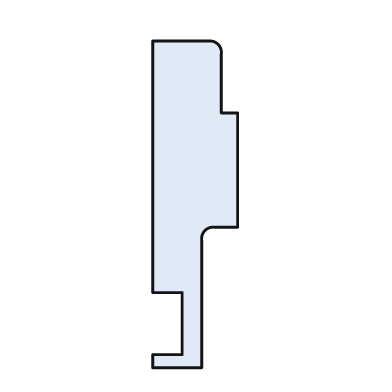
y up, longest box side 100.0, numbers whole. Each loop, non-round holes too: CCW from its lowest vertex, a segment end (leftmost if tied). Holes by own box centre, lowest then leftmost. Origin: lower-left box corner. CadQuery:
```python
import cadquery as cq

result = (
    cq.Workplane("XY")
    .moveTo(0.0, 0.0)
    .lineTo(15.0, 0.0)
    .lineTo(15.0, 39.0)
    .threePointArc((16.0, 42.0), (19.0, 43.0))
    .lineTo(26.0, 43.0)
    .lineTo(26.0, 78.0)
    .lineTo(21.0, 78.0)
    .lineTo(21.0, 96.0)
    .threePointArc((20.0, 99.0), (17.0, 100.0))
    .lineTo(0.0, 100.0)
    .lineTo(0.0, 23.0)
    .lineTo(9.0, 23.0)
    .lineTo(9.0, 4.0)
    .lineTo(0.0, 4.0)
    .close()
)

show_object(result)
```